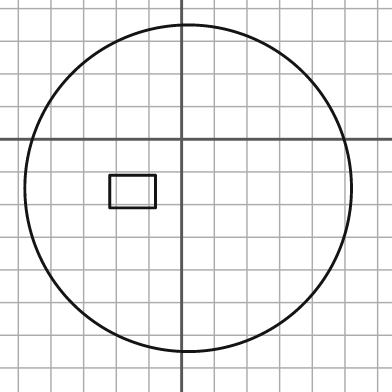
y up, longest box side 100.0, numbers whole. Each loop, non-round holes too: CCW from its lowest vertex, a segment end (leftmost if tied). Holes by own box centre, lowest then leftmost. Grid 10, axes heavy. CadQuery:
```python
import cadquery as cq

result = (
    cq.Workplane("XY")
    .moveTo(2.0, -15.0)
    .circle(50.0)
    .moveTo(-22.0, -21.0)
    .lineTo(-8.0, -21.0)
    .lineTo(-8.0, -11.0)
    .lineTo(-22.0, -11.0)
    .close()
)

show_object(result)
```